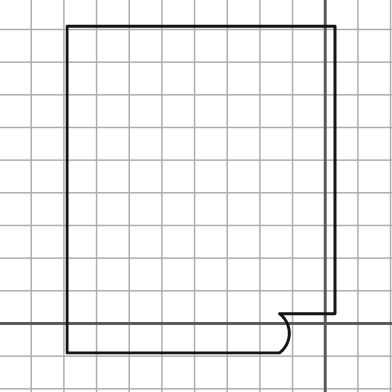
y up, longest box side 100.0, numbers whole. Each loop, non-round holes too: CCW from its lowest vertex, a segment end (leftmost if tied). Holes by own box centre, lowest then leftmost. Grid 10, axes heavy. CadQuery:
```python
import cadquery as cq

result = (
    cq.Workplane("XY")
    .moveTo(-79.0, -9.0)
    .lineTo(-14.0, -9.0)
    .threePointArc((-11.0, -3.0), (-14.0, 3.0))
    .lineTo(3.0, 3.0)
    .lineTo(3.0, 91.0)
    .lineTo(-79.0, 91.0)
    .close()
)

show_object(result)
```